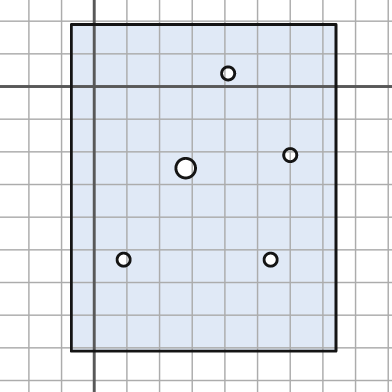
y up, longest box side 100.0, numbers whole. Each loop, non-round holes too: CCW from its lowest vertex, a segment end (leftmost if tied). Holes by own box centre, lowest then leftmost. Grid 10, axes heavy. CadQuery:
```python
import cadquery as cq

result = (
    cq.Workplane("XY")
    .moveTo(-7.0, -81.0)
    .lineTo(74.0, -81.0)
    .lineTo(74.0, 19.0)
    .lineTo(-7.0, 19.0)
    .close()
    .moveTo(9.0, -53.0)
    .circle(2.0)
    .moveTo(54.0, -53.0)
    .circle(2.0)
    .moveTo(28.0, -25.0)
    .circle(3.0)
    .moveTo(60.0, -21.0)
    .circle(2.0)
    .moveTo(41.0, 4.0)
    .circle(2.0)
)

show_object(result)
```